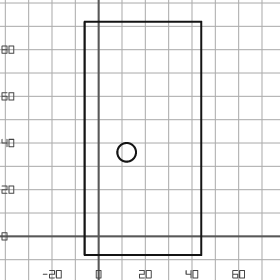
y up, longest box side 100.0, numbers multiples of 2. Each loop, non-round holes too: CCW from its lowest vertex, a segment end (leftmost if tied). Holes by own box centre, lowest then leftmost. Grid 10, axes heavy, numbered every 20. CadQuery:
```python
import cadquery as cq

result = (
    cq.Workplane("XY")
    .moveTo(-6.0, -8.0)
    .lineTo(44.0, -8.0)
    .lineTo(44.0, 92.0)
    .lineTo(-6.0, 92.0)
    .close()
    .moveTo(12.0, 36.0)
    .circle(4.0)
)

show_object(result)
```